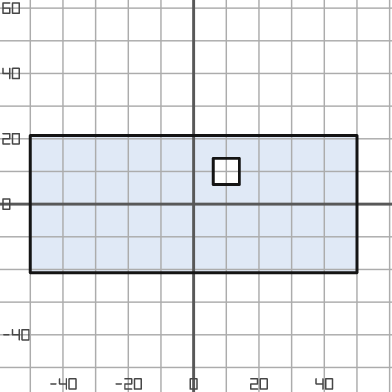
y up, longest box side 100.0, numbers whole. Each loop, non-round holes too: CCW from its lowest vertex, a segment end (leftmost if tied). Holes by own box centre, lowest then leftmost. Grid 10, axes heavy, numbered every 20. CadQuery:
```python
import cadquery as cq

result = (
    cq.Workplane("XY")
    .moveTo(-50.0, -21.0)
    .lineTo(50.0, -21.0)
    .lineTo(50.0, 21.0)
    .lineTo(-50.0, 21.0)
    .close()
    .moveTo(6.0, 6.0)
    .lineTo(14.0, 6.0)
    .lineTo(14.0, 14.0)
    .lineTo(6.0, 14.0)
    .close()
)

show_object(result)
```